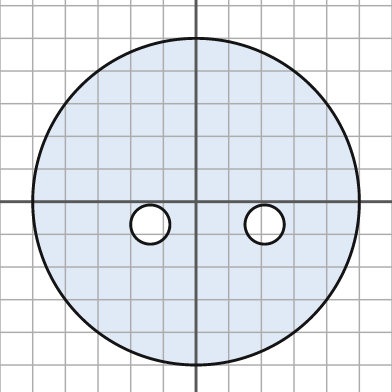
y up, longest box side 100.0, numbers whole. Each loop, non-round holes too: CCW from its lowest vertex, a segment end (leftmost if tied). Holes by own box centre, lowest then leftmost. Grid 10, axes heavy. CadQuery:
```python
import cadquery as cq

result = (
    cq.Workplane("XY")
    .moveTo(0.0, 0.0)
    .circle(50.0)
    .moveTo(-14.0, -7.0)
    .circle(6.0)
    .moveTo(21.0, -7.0)
    .circle(6.0)
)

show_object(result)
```